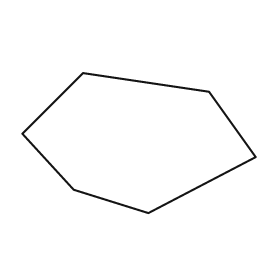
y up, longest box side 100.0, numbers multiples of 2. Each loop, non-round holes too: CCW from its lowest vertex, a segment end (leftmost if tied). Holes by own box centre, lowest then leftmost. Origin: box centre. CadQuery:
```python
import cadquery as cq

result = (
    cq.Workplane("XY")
    .moveTo(4.0, -30.0)
    .lineTo(50.0, -6.0)
    .lineTo(30.0, 22.0)
    .lineTo(-24.0, 30.0)
    .lineTo(-50.0, 4.0)
    .lineTo(-28.0, -20.0)
    .close()
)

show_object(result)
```